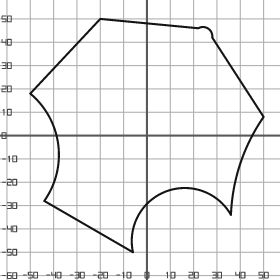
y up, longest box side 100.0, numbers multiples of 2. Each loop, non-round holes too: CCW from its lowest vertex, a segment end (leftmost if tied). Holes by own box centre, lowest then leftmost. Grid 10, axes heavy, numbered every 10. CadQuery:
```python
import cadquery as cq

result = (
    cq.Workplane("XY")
    .moveTo(-6.0, -50.0)
    .threePointArc((8.0, -24.0), (36.0, -34.0))
    .threePointArc((40.0, -12.0), (50.0, 8.0))
    .lineTo(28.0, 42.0)
    .threePointArc((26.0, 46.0), (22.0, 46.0))
    .lineTo(-20.0, 50.0)
    .lineTo(-50.0, 18.0)
    .threePointArc((-38.0, -4.0), (-44.0, -28.0))
    .close()
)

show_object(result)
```